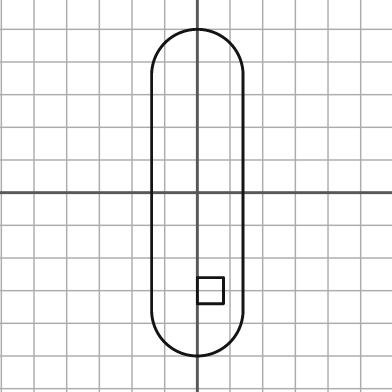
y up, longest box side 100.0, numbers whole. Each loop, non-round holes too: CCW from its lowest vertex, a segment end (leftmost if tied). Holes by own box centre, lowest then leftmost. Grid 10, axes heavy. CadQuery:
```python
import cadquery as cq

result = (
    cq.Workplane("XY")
    .moveTo(-14.0, -36.0)
    .threePointArc((0.0, -50.0), (14.0, -36.0))
    .lineTo(14.0, 36.0)
    .threePointArc((0.0, 50.0), (-14.0, 36.0))
    .close()
    .moveTo(0.0, -34.0)
    .lineTo(8.0, -34.0)
    .lineTo(8.0, -26.0)
    .lineTo(0.0, -26.0)
    .close()
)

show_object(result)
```